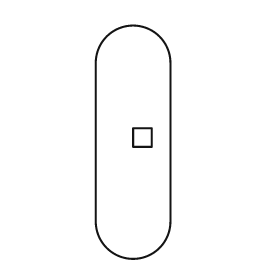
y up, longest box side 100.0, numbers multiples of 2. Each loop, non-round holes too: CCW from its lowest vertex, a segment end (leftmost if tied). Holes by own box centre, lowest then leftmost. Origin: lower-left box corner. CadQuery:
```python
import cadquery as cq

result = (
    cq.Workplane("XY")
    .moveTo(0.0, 16.0)
    .threePointArc((16.0, 0.0), (32.0, 16.0))
    .lineTo(32.0, 84.0)
    .threePointArc((16.0, 100.0), (0.0, 84.0))
    .close()
    .moveTo(16.0, 48.0)
    .lineTo(24.0, 48.0)
    .lineTo(24.0, 56.0)
    .lineTo(16.0, 56.0)
    .close()
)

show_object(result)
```